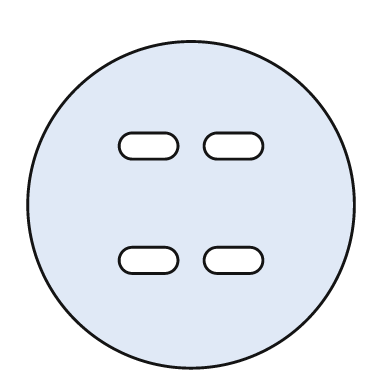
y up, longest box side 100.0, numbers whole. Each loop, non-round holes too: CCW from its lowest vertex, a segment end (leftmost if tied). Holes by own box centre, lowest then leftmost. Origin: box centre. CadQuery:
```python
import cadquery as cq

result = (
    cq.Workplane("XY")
    .moveTo(0.0, 0.0)
    .circle(50.0)
    .moveTo(-18.0, -21.0)
    .lineTo(-8.0, -21.0)
    .threePointArc((-4.0, -17.0), (-8.0, -13.0))
    .lineTo(-18.0, -13.0)
    .threePointArc((-22.0, -17.0), (-18.0, -21.0))
    .close()
    .moveTo(8.0, -21.0)
    .lineTo(18.0, -21.0)
    .threePointArc((22.0, -17.0), (18.0, -13.0))
    .lineTo(8.0, -13.0)
    .threePointArc((4.0, -17.0), (8.0, -21.0))
    .close()
    .moveTo(-18.0, 14.0)
    .lineTo(-8.0, 14.0)
    .threePointArc((-4.0, 18.0), (-8.0, 22.0))
    .lineTo(-18.0, 22.0)
    .threePointArc((-22.0, 18.0), (-18.0, 14.0))
    .close()
    .moveTo(8.0, 14.0)
    .lineTo(18.0, 14.0)
    .threePointArc((22.0, 18.0), (18.0, 22.0))
    .lineTo(8.0, 22.0)
    .threePointArc((4.0, 18.0), (8.0, 14.0))
    .close()
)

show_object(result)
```